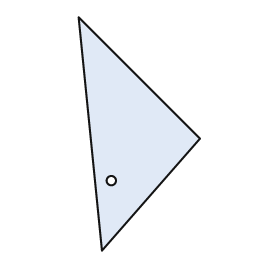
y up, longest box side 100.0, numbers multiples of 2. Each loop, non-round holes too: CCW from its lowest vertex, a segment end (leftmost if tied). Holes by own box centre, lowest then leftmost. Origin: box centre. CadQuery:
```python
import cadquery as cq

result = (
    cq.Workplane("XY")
    .moveTo(-16.0, -50.0)
    .lineTo(26.0, -2.0)
    .lineTo(-26.0, 50.0)
    .close()
    .moveTo(-12.0, -20.0)
    .circle(2.0)
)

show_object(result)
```